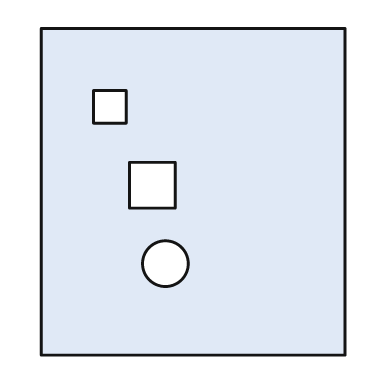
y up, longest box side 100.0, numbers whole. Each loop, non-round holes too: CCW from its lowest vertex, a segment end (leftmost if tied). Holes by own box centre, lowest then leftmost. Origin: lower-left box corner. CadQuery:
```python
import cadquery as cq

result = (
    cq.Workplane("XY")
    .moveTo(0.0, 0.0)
    .lineTo(93.0, 0.0)
    .lineTo(93.0, 100.0)
    .lineTo(0.0, 100.0)
    .close()
    .moveTo(38.0, 28.0)
    .circle(7.0)
    .moveTo(27.0, 45.0)
    .lineTo(41.0, 45.0)
    .lineTo(41.0, 59.0)
    .lineTo(27.0, 59.0)
    .close()
    .moveTo(16.0, 71.0)
    .lineTo(26.0, 71.0)
    .lineTo(26.0, 81.0)
    .lineTo(16.0, 81.0)
    .close()
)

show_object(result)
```